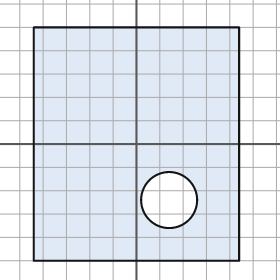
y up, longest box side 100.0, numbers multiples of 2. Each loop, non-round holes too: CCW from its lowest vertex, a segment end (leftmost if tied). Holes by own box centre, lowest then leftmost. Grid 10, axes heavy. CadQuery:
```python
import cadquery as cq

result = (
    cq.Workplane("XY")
    .moveTo(-44.0, -50.0)
    .lineTo(44.0, -50.0)
    .lineTo(44.0, 50.0)
    .lineTo(-44.0, 50.0)
    .close()
    .moveTo(14.0, -24.0)
    .circle(12.0)
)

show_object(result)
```